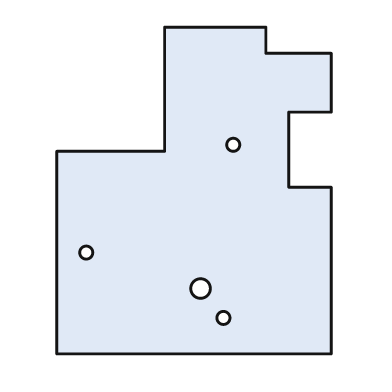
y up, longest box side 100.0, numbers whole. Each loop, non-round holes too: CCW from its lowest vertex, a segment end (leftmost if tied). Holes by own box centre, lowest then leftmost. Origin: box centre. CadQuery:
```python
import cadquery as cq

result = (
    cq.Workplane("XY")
    .moveTo(-42.0, -50.0)
    .lineTo(42.0, -50.0)
    .lineTo(42.0, 1.0)
    .lineTo(29.0, 1.0)
    .lineTo(29.0, 24.0)
    .lineTo(42.0, 24.0)
    .lineTo(42.0, 42.0)
    .lineTo(22.0, 42.0)
    .lineTo(22.0, 50.0)
    .lineTo(-9.0, 50.0)
    .lineTo(-9.0, 12.0)
    .lineTo(-42.0, 12.0)
    .close()
    .moveTo(9.0, -39.0)
    .circle(2.0)
    .moveTo(2.0, -30.0)
    .circle(3.0)
    .moveTo(-33.0, -19.0)
    .circle(2.0)
    .moveTo(12.0, 14.0)
    .circle(2.0)
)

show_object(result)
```